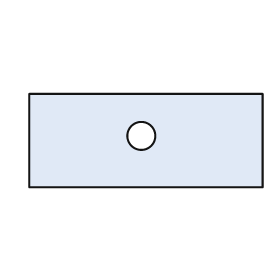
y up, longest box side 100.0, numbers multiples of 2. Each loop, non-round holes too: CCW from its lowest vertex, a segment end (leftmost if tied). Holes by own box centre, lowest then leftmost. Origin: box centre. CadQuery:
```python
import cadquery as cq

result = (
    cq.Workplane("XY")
    .moveTo(-50.0, -20.0)
    .lineTo(50.0, -20.0)
    .lineTo(50.0, 20.0)
    .lineTo(-50.0, 20.0)
    .close()
    .moveTo(-2.0, 2.0)
    .circle(6.0)
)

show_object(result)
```